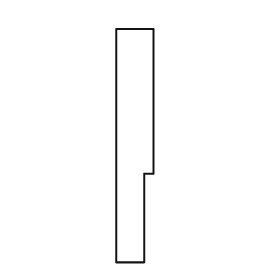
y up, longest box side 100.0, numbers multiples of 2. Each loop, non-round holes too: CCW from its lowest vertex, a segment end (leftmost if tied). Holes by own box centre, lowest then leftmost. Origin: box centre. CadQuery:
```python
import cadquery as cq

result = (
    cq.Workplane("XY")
    .moveTo(-8.0, -50.0)
    .lineTo(4.0, -50.0)
    .lineTo(4.0, -12.0)
    .lineTo(8.0, -12.0)
    .lineTo(8.0, 50.0)
    .lineTo(-8.0, 50.0)
    .close()
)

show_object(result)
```